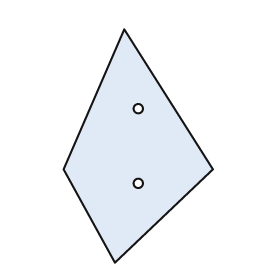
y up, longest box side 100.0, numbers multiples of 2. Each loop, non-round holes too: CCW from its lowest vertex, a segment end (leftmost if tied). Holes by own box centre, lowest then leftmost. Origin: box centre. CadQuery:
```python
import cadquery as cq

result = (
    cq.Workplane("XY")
    .moveTo(-10.0, -50.0)
    .lineTo(32.0, -10.0)
    .lineTo(-6.0, 50.0)
    .lineTo(-32.0, -10.0)
    .close()
    .moveTo(0.0, -16.0)
    .circle(2.0)
    .moveTo(0.0, 16.0)
    .circle(2.0)
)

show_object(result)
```